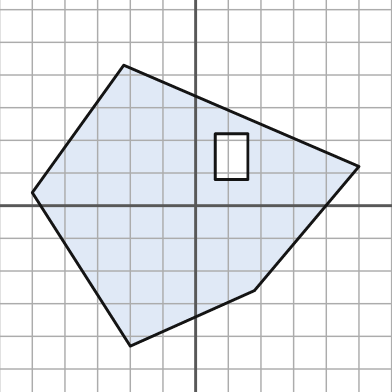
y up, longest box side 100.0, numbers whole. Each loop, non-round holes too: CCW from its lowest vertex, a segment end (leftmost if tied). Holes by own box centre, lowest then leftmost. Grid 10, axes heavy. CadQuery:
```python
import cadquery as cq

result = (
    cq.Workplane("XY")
    .moveTo(-20.0, -43.0)
    .lineTo(18.0, -26.0)
    .lineTo(50.0, 12.0)
    .lineTo(-22.0, 43.0)
    .lineTo(-50.0, 4.0)
    .close()
    .moveTo(6.0, 8.0)
    .lineTo(16.0, 8.0)
    .lineTo(16.0, 22.0)
    .lineTo(6.0, 22.0)
    .close()
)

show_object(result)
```